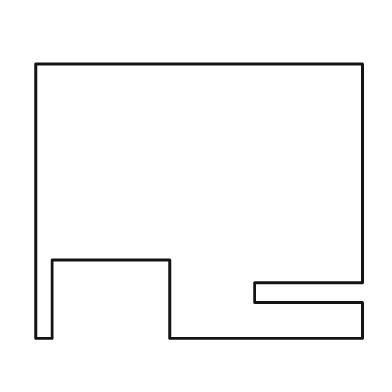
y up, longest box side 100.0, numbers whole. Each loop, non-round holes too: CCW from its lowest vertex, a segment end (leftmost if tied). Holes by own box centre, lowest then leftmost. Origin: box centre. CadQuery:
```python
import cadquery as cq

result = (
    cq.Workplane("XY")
    .moveTo(-50.0, -42.0)
    .lineTo(-45.0, -42.0)
    .lineTo(-45.0, -18.0)
    .lineTo(-9.0, -18.0)
    .lineTo(-9.0, -42.0)
    .lineTo(50.0, -42.0)
    .lineTo(50.0, -31.0)
    .lineTo(17.0, -31.0)
    .lineTo(17.0, -25.0)
    .lineTo(50.0, -25.0)
    .lineTo(50.0, 42.0)
    .lineTo(-50.0, 42.0)
    .close()
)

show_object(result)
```